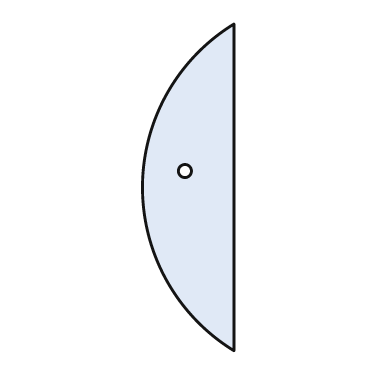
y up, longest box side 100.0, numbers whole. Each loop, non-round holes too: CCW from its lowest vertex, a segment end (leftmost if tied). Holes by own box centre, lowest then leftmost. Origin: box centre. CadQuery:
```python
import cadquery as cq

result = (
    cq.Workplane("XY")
    .moveTo(14.0, -50.0)
    .lineTo(14.0, 50.0)
    .threePointArc((-14.0, 0.0), (14.0, -50.0))
    .close()
    .moveTo(-1.0, 5.0)
    .circle(2.0)
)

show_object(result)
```